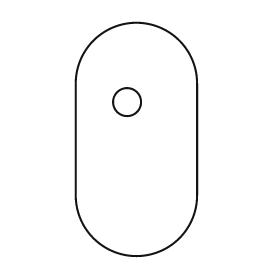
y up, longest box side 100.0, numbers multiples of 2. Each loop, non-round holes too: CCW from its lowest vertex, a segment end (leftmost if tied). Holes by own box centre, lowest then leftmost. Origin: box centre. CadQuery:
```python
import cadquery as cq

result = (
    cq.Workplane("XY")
    .moveTo(-26.0, -24.0)
    .threePointArc((0.0, -50.0), (26.0, -24.0))
    .lineTo(26.0, 24.0)
    .threePointArc((0.0, 50.0), (-26.0, 24.0))
    .close()
    .moveTo(-4.0, 16.0)
    .circle(6.0)
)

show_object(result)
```